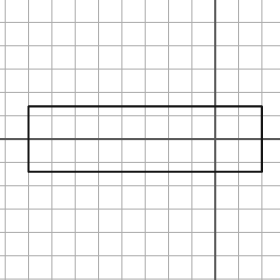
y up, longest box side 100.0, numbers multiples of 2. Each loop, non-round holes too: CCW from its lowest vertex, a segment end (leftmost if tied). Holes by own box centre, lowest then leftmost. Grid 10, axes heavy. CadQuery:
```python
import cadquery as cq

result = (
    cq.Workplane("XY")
    .moveTo(-80.0, -14.0)
    .lineTo(20.0, -14.0)
    .lineTo(20.0, 14.0)
    .lineTo(-80.0, 14.0)
    .close()
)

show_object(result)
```